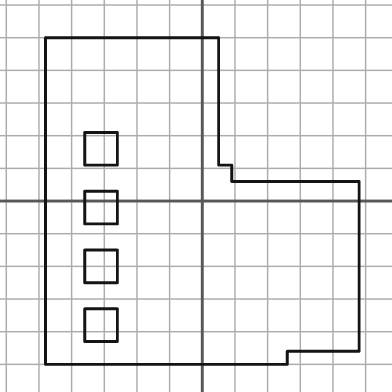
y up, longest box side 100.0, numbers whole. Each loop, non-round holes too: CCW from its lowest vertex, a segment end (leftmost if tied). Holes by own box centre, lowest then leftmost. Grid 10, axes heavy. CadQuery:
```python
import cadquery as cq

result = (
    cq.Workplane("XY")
    .moveTo(-48.0, -50.0)
    .lineTo(26.0, -50.0)
    .lineTo(26.0, -46.0)
    .lineTo(48.0, -46.0)
    .lineTo(48.0, 6.0)
    .lineTo(9.0, 6.0)
    .lineTo(9.0, 11.0)
    .lineTo(5.0, 11.0)
    .lineTo(5.0, 50.0)
    .lineTo(-48.0, 50.0)
    .close()
    .moveTo(-36.0, -43.0)
    .lineTo(-26.0, -43.0)
    .lineTo(-26.0, -33.0)
    .lineTo(-36.0, -33.0)
    .close()
    .moveTo(-36.0, -25.0)
    .lineTo(-26.0, -25.0)
    .lineTo(-26.0, -15.0)
    .lineTo(-36.0, -15.0)
    .close()
    .moveTo(-36.0, -7.0)
    .lineTo(-26.0, -7.0)
    .lineTo(-26.0, 3.0)
    .lineTo(-36.0, 3.0)
    .close()
    .moveTo(-36.0, 11.0)
    .lineTo(-26.0, 11.0)
    .lineTo(-26.0, 21.0)
    .lineTo(-36.0, 21.0)
    .close()
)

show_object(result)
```